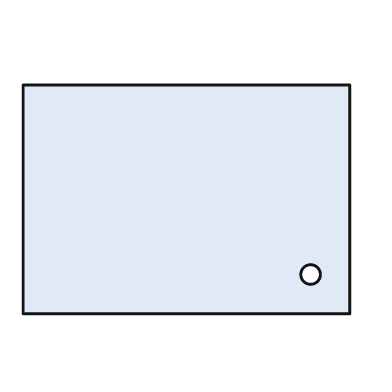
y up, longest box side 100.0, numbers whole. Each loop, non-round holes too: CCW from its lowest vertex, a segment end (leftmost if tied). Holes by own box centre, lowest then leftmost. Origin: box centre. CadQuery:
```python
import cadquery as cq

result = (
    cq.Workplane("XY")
    .moveTo(-50.0, -35.0)
    .lineTo(50.0, -35.0)
    .lineTo(50.0, 35.0)
    .lineTo(-50.0, 35.0)
    .close()
    .moveTo(38.0, -23.0)
    .circle(3.0)
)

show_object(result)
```